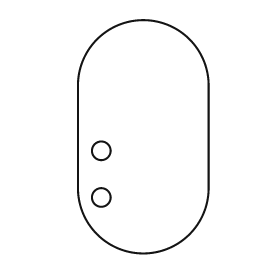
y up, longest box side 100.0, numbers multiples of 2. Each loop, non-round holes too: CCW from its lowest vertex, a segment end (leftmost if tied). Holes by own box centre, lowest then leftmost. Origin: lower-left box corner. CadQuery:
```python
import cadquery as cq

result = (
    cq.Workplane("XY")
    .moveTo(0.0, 28.0)
    .threePointArc((28.0, 0.0), (56.0, 28.0))
    .lineTo(56.0, 72.0)
    .threePointArc((28.0, 100.0), (0.0, 72.0))
    .close()
    .moveTo(10.0, 24.0)
    .circle(4.0)
    .moveTo(10.0, 44.0)
    .circle(4.0)
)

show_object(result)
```